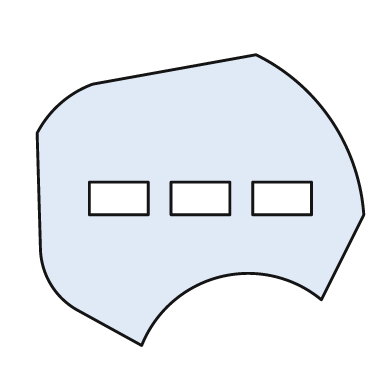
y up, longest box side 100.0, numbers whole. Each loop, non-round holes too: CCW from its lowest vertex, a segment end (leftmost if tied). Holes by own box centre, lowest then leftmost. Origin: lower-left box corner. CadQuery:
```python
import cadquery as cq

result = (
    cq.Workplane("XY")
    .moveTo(32.0, 0.0)
    .threePointArc((56.0, 21.0), (87.0, 14.0))
    .lineTo(100.0, 40.0)
    .threePointArc((90.0, 69.0), (67.0, 89.0))
    .lineTo(17.0, 80.0)
    .threePointArc((7.0, 74.0), (0.0, 65.0))
    .lineTo(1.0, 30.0)
    .threePointArc((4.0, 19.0), (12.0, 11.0))
    .close()
    .moveTo(16.0, 40.0)
    .lineTo(34.0, 40.0)
    .lineTo(34.0, 50.0)
    .lineTo(16.0, 50.0)
    .close()
    .moveTo(41.0, 40.0)
    .lineTo(59.0, 40.0)
    .lineTo(59.0, 50.0)
    .lineTo(41.0, 50.0)
    .close()
    .moveTo(66.0, 40.0)
    .lineTo(84.0, 40.0)
    .lineTo(84.0, 50.0)
    .lineTo(66.0, 50.0)
    .close()
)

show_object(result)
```